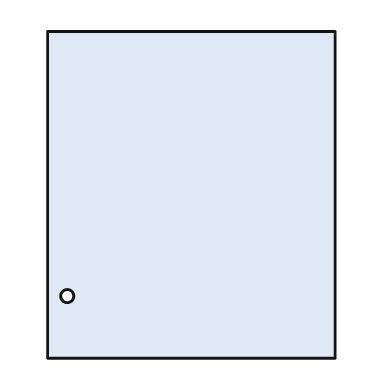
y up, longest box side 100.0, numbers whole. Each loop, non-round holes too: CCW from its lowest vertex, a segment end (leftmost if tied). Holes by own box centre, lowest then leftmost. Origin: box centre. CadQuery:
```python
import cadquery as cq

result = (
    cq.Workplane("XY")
    .moveTo(-44.0, -50.0)
    .lineTo(44.0, -50.0)
    .lineTo(44.0, 50.0)
    .lineTo(-44.0, 50.0)
    .close()
    .moveTo(-38.0, -31.0)
    .circle(2.0)
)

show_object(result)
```